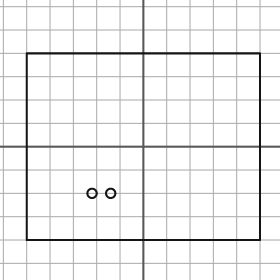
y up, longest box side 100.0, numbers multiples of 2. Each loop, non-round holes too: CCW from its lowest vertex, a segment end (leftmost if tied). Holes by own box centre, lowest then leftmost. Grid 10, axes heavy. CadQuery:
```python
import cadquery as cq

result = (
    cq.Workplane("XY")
    .moveTo(-50.0, -40.0)
    .lineTo(50.0, -40.0)
    .lineTo(50.0, 40.0)
    .lineTo(-50.0, 40.0)
    .close()
    .moveTo(-22.0, -20.0)
    .circle(2.0)
    .moveTo(-14.0, -20.0)
    .circle(2.0)
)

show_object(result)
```